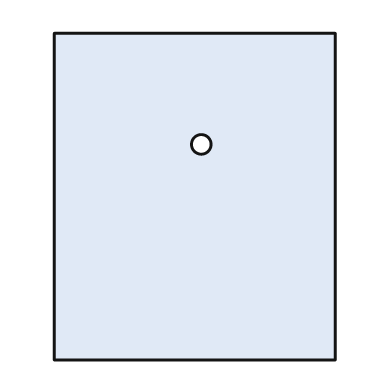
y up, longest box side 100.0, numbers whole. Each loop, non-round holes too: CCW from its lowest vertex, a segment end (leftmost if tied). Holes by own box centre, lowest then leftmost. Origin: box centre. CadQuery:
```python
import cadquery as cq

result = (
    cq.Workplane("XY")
    .moveTo(-43.0, -50.0)
    .lineTo(43.0, -50.0)
    .lineTo(43.0, 50.0)
    .lineTo(-43.0, 50.0)
    .close()
    .moveTo(2.0, 16.0)
    .circle(3.0)
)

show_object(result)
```